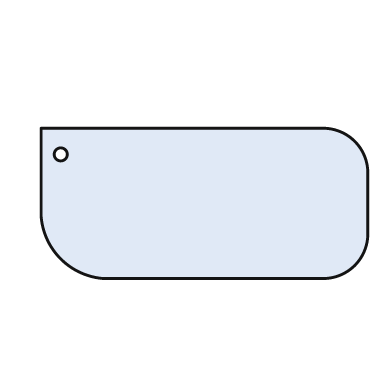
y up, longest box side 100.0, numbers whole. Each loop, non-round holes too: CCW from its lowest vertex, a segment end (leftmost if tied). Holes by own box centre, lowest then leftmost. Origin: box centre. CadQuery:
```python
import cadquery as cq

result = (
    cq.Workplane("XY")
    .moveTo(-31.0, -23.0)
    .lineTo(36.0, -23.0)
    .threePointArc((46.0, -19.0), (50.0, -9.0))
    .lineTo(50.0, 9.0)
    .threePointArc((46.0, 19.0), (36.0, 23.0))
    .lineTo(-50.0, 23.0)
    .lineTo(-50.0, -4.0)
    .threePointArc((-44.0, -17.0), (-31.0, -23.0))
    .close()
    .moveTo(-44.0, 15.0)
    .circle(2.0)
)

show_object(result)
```